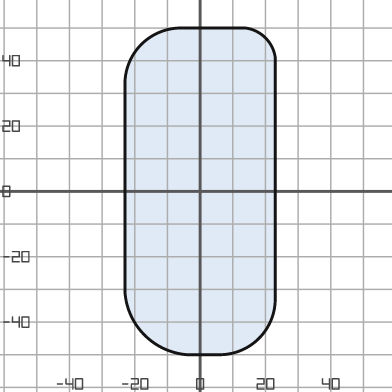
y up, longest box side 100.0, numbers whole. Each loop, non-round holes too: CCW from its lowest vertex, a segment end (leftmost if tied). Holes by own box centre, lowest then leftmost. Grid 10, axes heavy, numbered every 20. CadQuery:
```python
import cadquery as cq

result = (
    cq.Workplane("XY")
    .moveTo(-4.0, -50.0)
    .lineTo(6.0, -50.0)
    .threePointArc((18.0, -45.0), (23.0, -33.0))
    .lineTo(23.0, 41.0)
    .threePointArc((20.0, 47.0), (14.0, 50.0))
    .lineTo(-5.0, 50.0)
    .threePointArc((-18.0, 45.0), (-23.0, 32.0))
    .lineTo(-23.0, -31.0)
    .threePointArc((-17.0, -44.0), (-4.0, -50.0))
    .close()
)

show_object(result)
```